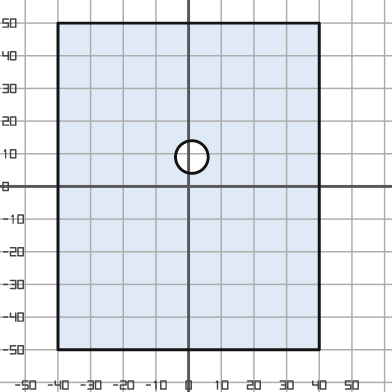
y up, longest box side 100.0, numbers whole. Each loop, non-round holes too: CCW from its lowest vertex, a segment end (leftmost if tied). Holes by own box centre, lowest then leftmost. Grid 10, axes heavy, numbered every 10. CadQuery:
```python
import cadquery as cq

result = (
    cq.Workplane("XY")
    .moveTo(-40.0, -50.0)
    .lineTo(40.0, -50.0)
    .lineTo(40.0, 50.0)
    .lineTo(-40.0, 50.0)
    .close()
    .moveTo(1.0, 9.0)
    .circle(5.0)
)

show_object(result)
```